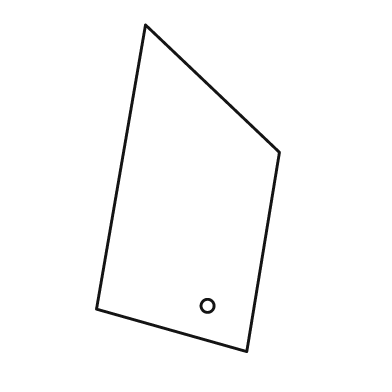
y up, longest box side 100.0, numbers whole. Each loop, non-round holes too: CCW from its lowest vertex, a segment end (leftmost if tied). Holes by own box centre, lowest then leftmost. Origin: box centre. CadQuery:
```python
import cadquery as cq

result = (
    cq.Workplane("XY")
    .moveTo(18.0, -50.0)
    .lineTo(28.0, 11.0)
    .lineTo(-13.0, 50.0)
    .lineTo(-28.0, -37.0)
    .close()
    .moveTo(6.0, -36.0)
    .circle(2.0)
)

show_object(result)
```